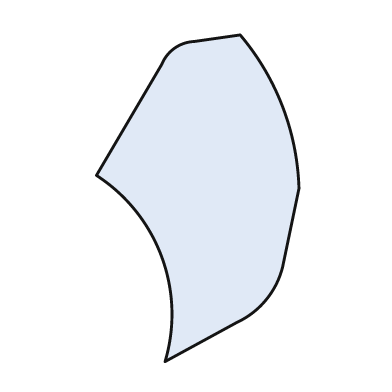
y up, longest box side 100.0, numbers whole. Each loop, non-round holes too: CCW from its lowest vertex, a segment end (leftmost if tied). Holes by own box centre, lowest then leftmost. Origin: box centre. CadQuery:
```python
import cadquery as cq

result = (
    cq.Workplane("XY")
    .moveTo(-10.0, -50.0)
    .lineTo(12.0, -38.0)
    .threePointArc((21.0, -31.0), (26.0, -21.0))
    .lineTo(31.0, 3.0)
    .threePointArc((26.0, 28.0), (13.0, 50.0))
    .lineTo(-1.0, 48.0)
    .threePointArc((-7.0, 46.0), (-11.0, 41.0))
    .lineTo(-31.0, 7.0)
    .threePointArc((-11.0, -18.0), (-10.0, -50.0))
    .close()
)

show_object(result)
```